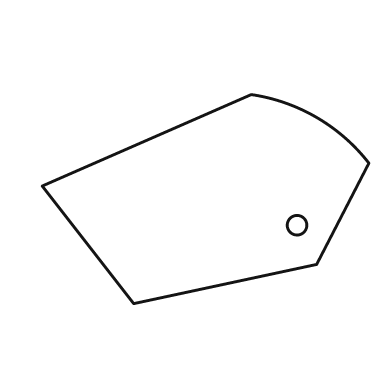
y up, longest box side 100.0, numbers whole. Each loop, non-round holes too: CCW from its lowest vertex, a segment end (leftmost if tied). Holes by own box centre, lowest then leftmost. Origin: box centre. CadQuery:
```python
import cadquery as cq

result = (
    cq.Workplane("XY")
    .moveTo(-22.0, -32.0)
    .lineTo(34.0, -20.0)
    .lineTo(50.0, 11.0)
    .threePointArc((34.0, 25.0), (14.0, 32.0))
    .lineTo(-50.0, 4.0)
    .close()
    .moveTo(28.0, -8.0)
    .circle(3.0)
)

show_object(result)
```